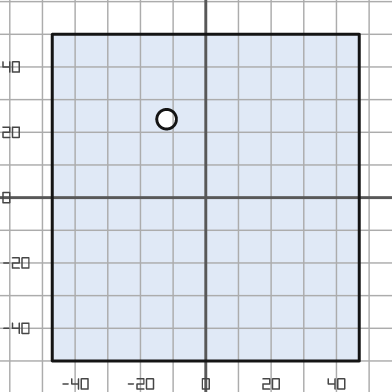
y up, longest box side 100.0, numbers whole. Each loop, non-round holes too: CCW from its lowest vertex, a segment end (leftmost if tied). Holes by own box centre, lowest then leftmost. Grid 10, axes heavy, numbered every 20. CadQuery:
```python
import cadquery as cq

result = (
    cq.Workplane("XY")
    .moveTo(-47.0, -50.0)
    .lineTo(47.0, -50.0)
    .lineTo(47.0, 50.0)
    .lineTo(-47.0, 50.0)
    .close()
    .moveTo(-12.0, 24.0)
    .circle(3.0)
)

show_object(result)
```